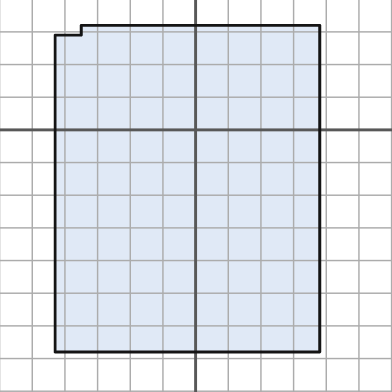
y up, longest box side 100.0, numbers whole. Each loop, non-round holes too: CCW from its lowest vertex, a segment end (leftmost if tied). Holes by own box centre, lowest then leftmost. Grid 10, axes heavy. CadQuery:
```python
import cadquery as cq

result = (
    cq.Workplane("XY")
    .moveTo(-43.0, -68.0)
    .lineTo(38.0, -68.0)
    .lineTo(38.0, 32.0)
    .lineTo(-35.0, 32.0)
    .lineTo(-35.0, 29.0)
    .lineTo(-43.0, 29.0)
    .close()
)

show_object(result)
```